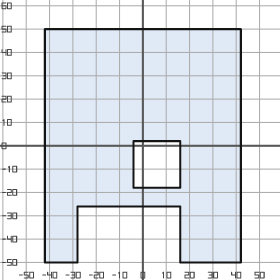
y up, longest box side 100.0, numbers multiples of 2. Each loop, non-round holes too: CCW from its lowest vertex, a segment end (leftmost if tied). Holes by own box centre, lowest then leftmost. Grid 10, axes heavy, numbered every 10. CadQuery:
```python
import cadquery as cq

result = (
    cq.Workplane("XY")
    .moveTo(-42.0, -50.0)
    .lineTo(-28.0, -50.0)
    .lineTo(-28.0, -26.0)
    .lineTo(16.0, -26.0)
    .lineTo(16.0, -50.0)
    .lineTo(42.0, -50.0)
    .lineTo(42.0, 50.0)
    .lineTo(-42.0, 50.0)
    .close()
    .moveTo(-4.0, -18.0)
    .lineTo(16.0, -18.0)
    .lineTo(16.0, 2.0)
    .lineTo(-4.0, 2.0)
    .close()
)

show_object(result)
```